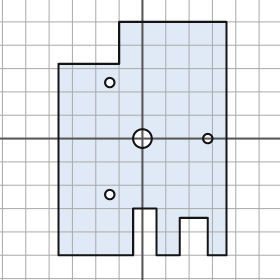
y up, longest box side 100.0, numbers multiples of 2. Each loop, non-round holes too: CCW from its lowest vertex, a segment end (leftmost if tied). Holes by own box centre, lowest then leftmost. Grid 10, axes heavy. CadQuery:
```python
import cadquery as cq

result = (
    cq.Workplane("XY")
    .moveTo(-36.0, -50.0)
    .lineTo(-4.0, -50.0)
    .lineTo(-4.0, -30.0)
    .lineTo(6.0, -30.0)
    .lineTo(6.0, -50.0)
    .lineTo(16.0, -50.0)
    .lineTo(16.0, -34.0)
    .lineTo(28.0, -34.0)
    .lineTo(28.0, -50.0)
    .lineTo(36.0, -50.0)
    .lineTo(36.0, 50.0)
    .lineTo(-10.0, 50.0)
    .lineTo(-10.0, 32.0)
    .lineTo(-36.0, 32.0)
    .close()
    .moveTo(-14.0, -24.0)
    .circle(2.0)
    .moveTo(0.0, 0.0)
    .circle(4.0)
    .moveTo(28.0, 0.0)
    .circle(2.0)
    .moveTo(-14.0, 24.0)
    .circle(2.0)
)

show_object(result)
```